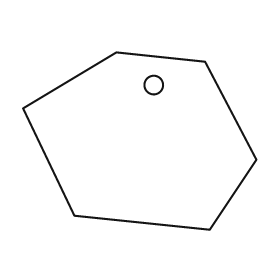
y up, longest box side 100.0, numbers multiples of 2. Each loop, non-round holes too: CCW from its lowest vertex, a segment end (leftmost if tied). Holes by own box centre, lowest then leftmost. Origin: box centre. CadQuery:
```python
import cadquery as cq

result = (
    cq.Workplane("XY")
    .moveTo(30.0, -38.0)
    .lineTo(50.0, -8.0)
    .lineTo(28.0, 34.0)
    .lineTo(-10.0, 38.0)
    .lineTo(-50.0, 14.0)
    .lineTo(-28.0, -32.0)
    .close()
    .moveTo(6.0, 24.0)
    .circle(4.0)
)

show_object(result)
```